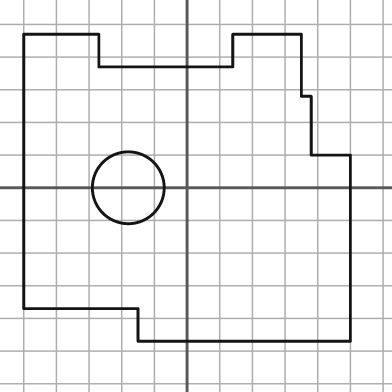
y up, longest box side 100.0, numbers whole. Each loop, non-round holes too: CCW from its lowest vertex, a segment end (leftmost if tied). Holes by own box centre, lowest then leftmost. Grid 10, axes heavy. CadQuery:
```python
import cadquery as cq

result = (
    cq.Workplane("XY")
    .moveTo(-15.0, -47.0)
    .lineTo(50.0, -47.0)
    .lineTo(50.0, 10.0)
    .lineTo(38.0, 10.0)
    .lineTo(38.0, 28.0)
    .lineTo(35.0, 28.0)
    .lineTo(35.0, 47.0)
    .lineTo(14.0, 47.0)
    .lineTo(14.0, 37.0)
    .lineTo(-27.0, 37.0)
    .lineTo(-27.0, 47.0)
    .lineTo(-50.0, 47.0)
    .lineTo(-50.0, -37.0)
    .lineTo(-15.0, -37.0)
    .close()
    .moveTo(-18.0, 0.0)
    .circle(11.0)
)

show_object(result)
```